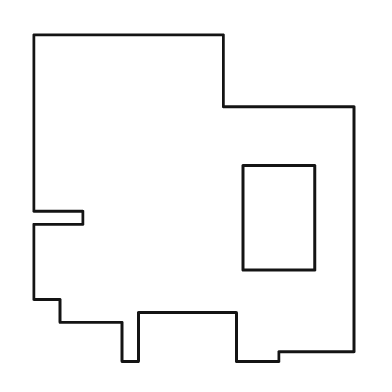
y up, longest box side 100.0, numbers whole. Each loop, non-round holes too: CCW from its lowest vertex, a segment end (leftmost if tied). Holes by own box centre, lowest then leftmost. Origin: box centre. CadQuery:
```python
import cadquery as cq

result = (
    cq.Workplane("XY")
    .moveTo(-22.0, -50.0)
    .lineTo(-17.0, -50.0)
    .lineTo(-17.0, -35.0)
    .lineTo(13.0, -35.0)
    .lineTo(13.0, -50.0)
    .lineTo(26.0, -50.0)
    .lineTo(26.0, -47.0)
    .lineTo(49.0, -47.0)
    .lineTo(49.0, 28.0)
    .lineTo(9.0, 28.0)
    .lineTo(9.0, 50.0)
    .lineTo(-49.0, 50.0)
    .lineTo(-49.0, -4.0)
    .lineTo(-34.0, -4.0)
    .lineTo(-34.0, -8.0)
    .lineTo(-49.0, -8.0)
    .lineTo(-49.0, -31.0)
    .lineTo(-41.0, -31.0)
    .lineTo(-41.0, -38.0)
    .lineTo(-22.0, -38.0)
    .close()
    .moveTo(15.0, -22.0)
    .lineTo(37.0, -22.0)
    .lineTo(37.0, 10.0)
    .lineTo(15.0, 10.0)
    .close()
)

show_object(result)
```